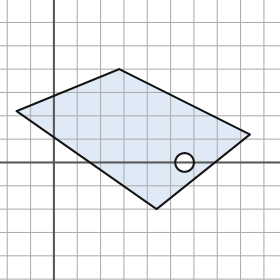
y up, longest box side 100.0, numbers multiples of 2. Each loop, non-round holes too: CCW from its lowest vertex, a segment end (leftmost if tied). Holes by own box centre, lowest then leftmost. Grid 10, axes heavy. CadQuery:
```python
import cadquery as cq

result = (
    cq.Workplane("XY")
    .moveTo(44.0, -20.0)
    .lineTo(84.0, 12.0)
    .lineTo(28.0, 40.0)
    .lineTo(-16.0, 22.0)
    .close()
    .moveTo(56.0, 0.0)
    .circle(4.0)
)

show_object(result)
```